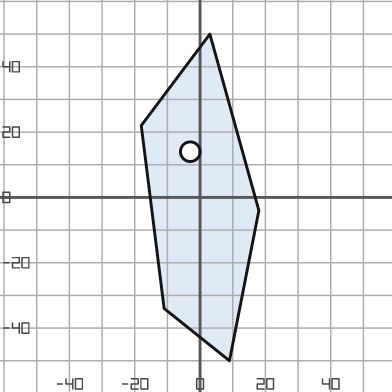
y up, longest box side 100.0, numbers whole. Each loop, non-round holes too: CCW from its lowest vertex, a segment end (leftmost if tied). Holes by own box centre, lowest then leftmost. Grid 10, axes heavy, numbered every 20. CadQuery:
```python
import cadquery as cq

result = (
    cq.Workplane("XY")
    .moveTo(9.0, -50.0)
    .lineTo(18.0, -4.0)
    .lineTo(3.0, 50.0)
    .lineTo(-18.0, 22.0)
    .lineTo(-11.0, -34.0)
    .close()
    .moveTo(-3.0, 14.0)
    .circle(3.0)
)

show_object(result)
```